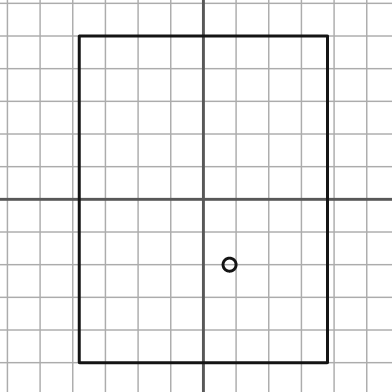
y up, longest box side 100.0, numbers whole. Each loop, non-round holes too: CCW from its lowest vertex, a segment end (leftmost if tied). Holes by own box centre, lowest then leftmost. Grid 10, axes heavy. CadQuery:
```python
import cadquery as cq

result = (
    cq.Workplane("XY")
    .moveTo(-38.0, -50.0)
    .lineTo(38.0, -50.0)
    .lineTo(38.0, 50.0)
    .lineTo(-38.0, 50.0)
    .close()
    .moveTo(8.0, -20.0)
    .circle(2.0)
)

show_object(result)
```